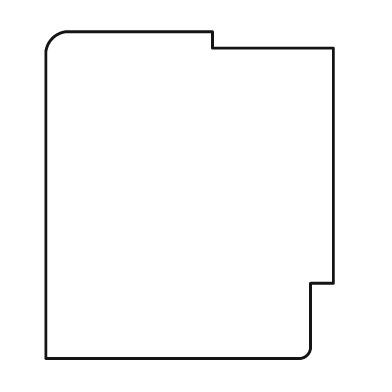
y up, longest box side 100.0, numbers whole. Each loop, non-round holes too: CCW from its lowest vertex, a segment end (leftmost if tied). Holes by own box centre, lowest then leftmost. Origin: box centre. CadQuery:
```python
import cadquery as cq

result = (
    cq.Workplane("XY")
    .moveTo(-44.0, -50.0)
    .lineTo(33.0, -50.0)
    .threePointArc((36.0, -49.0), (37.0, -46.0))
    .lineTo(37.0, -27.0)
    .lineTo(44.0, -27.0)
    .lineTo(44.0, 45.0)
    .lineTo(7.0, 45.0)
    .lineTo(7.0, 50.0)
    .lineTo(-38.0, 50.0)
    .threePointArc((-42.0, 48.0), (-44.0, 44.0))
    .close()
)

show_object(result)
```